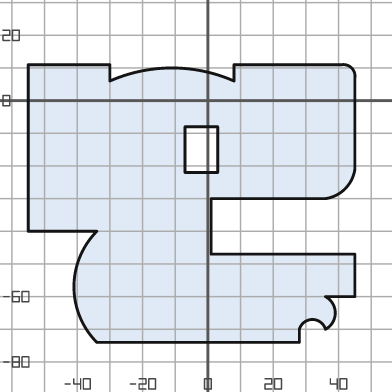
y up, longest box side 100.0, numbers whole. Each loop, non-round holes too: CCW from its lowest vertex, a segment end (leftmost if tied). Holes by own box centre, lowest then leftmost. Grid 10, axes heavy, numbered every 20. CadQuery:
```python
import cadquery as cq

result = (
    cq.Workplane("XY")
    .moveTo(-34.0, -74.0)
    .lineTo(28.0, -74.0)
    .lineTo(28.0, -70.0)
    .threePointArc((32.0, -67.0), (36.0, -70.0))
    .threePointArc((39.0, -65.0), (36.0, -60.0))
    .lineTo(45.0, -60.0)
    .lineTo(45.0, -47.0)
    .lineTo(1.0, -47.0)
    .lineTo(1.0, -30.0)
    .lineTo(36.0, -30.0)
    .threePointArc((42.0, -27.0), (45.0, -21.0))
    .lineTo(45.0, 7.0)
    .threePointArc((44.0, 10.0), (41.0, 11.0))
    .lineTo(8.0, 11.0)
    .lineTo(8.0, 6.0)
    .threePointArc((-11.0, 10.0), (-30.0, 6.0))
    .lineTo(-30.0, 11.0)
    .lineTo(-55.0, 11.0)
    .lineTo(-55.0, -40.0)
    .lineTo(-34.0, -40.0)
    .threePointArc((-41.0, -57.0), (-34.0, -74.0))
    .close()
    .moveTo(-7.0, -22.0)
    .lineTo(3.0, -22.0)
    .lineTo(3.0, -8.0)
    .lineTo(-7.0, -8.0)
    .close()
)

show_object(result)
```